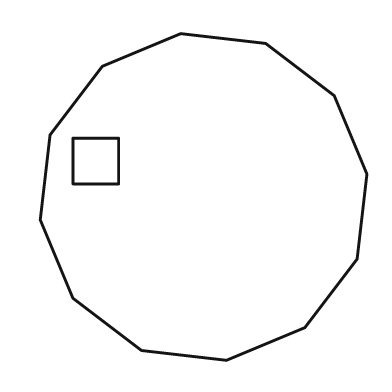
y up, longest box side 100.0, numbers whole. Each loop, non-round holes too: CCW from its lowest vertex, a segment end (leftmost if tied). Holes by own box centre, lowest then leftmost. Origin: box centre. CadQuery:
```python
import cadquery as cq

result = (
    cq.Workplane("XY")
    .moveTo(7.0, -50.0)
    .lineTo(31.0, -40.0)
    .lineTo(47.0, -19.0)
    .lineTo(50.0, 7.0)
    .lineTo(40.0, 31.0)
    .lineTo(19.0, 47.0)
    .lineTo(-7.0, 50.0)
    .lineTo(-31.0, 40.0)
    .lineTo(-47.0, 19.0)
    .lineTo(-50.0, -7.0)
    .lineTo(-40.0, -31.0)
    .lineTo(-19.0, -47.0)
    .close()
    .moveTo(-40.0, 4.0)
    .lineTo(-26.0, 4.0)
    .lineTo(-26.0, 18.0)
    .lineTo(-40.0, 18.0)
    .close()
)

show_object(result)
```